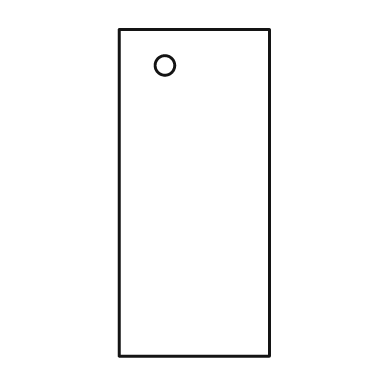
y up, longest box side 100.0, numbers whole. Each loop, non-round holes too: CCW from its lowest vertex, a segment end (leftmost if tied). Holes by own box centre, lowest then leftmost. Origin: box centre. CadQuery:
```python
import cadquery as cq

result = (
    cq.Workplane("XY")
    .moveTo(-23.0, -50.0)
    .lineTo(23.0, -50.0)
    .lineTo(23.0, 50.0)
    .lineTo(-23.0, 50.0)
    .close()
    .moveTo(-9.0, 39.0)
    .circle(3.0)
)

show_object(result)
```